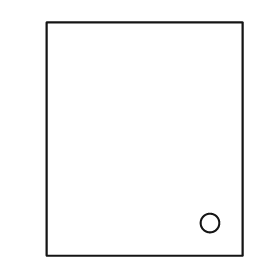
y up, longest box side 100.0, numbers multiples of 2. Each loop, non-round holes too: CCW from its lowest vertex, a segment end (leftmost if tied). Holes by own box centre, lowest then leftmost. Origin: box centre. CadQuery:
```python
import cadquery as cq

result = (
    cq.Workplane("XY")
    .moveTo(-42.0, -50.0)
    .lineTo(42.0, -50.0)
    .lineTo(42.0, 50.0)
    .lineTo(-42.0, 50.0)
    .close()
    .moveTo(28.0, -36.0)
    .circle(4.0)
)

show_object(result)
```